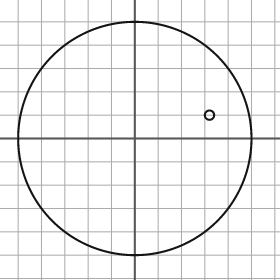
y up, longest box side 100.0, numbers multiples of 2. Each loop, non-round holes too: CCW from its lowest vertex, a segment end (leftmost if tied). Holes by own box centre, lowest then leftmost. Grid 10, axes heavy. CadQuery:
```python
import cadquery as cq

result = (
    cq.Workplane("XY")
    .moveTo(0.0, 0.0)
    .circle(50.0)
    .moveTo(32.0, 10.0)
    .circle(2.0)
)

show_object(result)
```